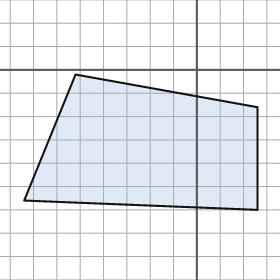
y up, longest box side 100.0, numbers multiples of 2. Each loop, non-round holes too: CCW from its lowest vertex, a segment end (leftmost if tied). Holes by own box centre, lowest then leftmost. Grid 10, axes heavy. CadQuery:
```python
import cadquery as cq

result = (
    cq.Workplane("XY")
    .moveTo(26.0, -60.0)
    .lineTo(26.0, -16.0)
    .lineTo(-52.0, -2.0)
    .lineTo(-74.0, -56.0)
    .close()
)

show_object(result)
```